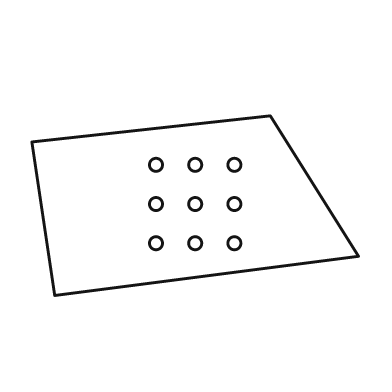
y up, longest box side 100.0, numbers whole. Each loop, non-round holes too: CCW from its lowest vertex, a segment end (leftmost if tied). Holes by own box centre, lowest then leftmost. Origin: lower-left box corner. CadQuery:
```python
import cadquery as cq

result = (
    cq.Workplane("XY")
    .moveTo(7.0, 0.0)
    .lineTo(100.0, 12.0)
    .lineTo(73.0, 55.0)
    .lineTo(0.0, 47.0)
    .close()
    .moveTo(38.0, 16.0)
    .circle(2.0)
    .moveTo(50.0, 16.0)
    .circle(2.0)
    .moveTo(62.0, 16.0)
    .circle(2.0)
    .moveTo(38.0, 28.0)
    .circle(2.0)
    .moveTo(50.0, 28.0)
    .circle(2.0)
    .moveTo(62.0, 28.0)
    .circle(2.0)
    .moveTo(38.0, 40.0)
    .circle(2.0)
    .moveTo(50.0, 40.0)
    .circle(2.0)
    .moveTo(62.0, 40.0)
    .circle(2.0)
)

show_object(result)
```